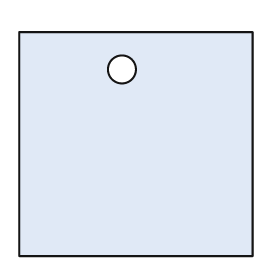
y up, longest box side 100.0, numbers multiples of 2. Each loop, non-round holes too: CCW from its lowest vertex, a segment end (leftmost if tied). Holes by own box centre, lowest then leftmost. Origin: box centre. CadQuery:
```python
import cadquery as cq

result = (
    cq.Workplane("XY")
    .moveTo(-50.0, -48.0)
    .lineTo(50.0, -48.0)
    .lineTo(50.0, 48.0)
    .lineTo(-50.0, 48.0)
    .close()
    .moveTo(-6.0, 32.0)
    .circle(6.0)
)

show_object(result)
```